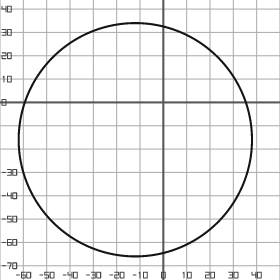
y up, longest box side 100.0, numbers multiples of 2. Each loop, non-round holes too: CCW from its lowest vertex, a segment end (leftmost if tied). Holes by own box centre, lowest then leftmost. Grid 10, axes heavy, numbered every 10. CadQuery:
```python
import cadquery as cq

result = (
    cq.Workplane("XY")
    .moveTo(-12.0, -16.0)
    .circle(50.0)
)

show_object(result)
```